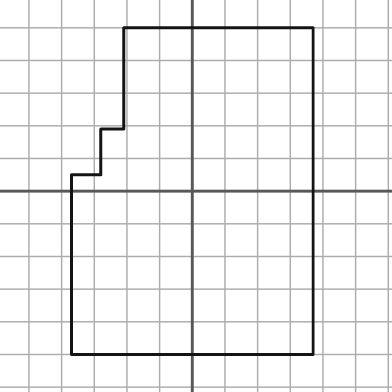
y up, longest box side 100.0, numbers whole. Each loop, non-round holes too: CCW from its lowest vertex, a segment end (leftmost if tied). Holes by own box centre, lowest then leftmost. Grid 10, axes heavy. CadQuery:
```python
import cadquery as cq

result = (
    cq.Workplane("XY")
    .moveTo(-37.0, -50.0)
    .lineTo(37.0, -50.0)
    .lineTo(37.0, 50.0)
    .lineTo(-21.0, 50.0)
    .lineTo(-21.0, 19.0)
    .lineTo(-28.0, 19.0)
    .lineTo(-28.0, 5.0)
    .lineTo(-37.0, 5.0)
    .close()
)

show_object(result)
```